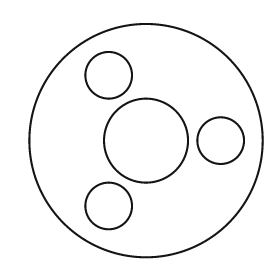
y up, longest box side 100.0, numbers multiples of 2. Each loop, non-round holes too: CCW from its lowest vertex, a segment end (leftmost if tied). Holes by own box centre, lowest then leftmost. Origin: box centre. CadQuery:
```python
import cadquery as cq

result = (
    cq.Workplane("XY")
    .moveTo(0.0, 0.0)
    .circle(50.0)
    .moveTo(-16.0, -28.0)
    .circle(10.0)
    .moveTo(0.0, 0.0)
    .circle(18.0)
    .moveTo(32.0, 0.0)
    .circle(10.0)
    .moveTo(-16.0, 28.0)
    .circle(10.0)
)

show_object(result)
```